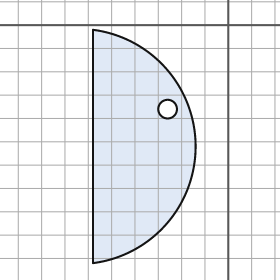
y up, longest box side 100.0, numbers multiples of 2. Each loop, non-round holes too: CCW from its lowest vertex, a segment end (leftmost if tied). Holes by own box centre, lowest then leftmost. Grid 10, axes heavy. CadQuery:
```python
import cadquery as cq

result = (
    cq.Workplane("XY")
    .moveTo(-58.0, -102.0)
    .threePointArc((-14.0, -52.0), (-58.0, -2.0))
    .close()
    .moveTo(-26.0, -36.0)
    .circle(4.0)
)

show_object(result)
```